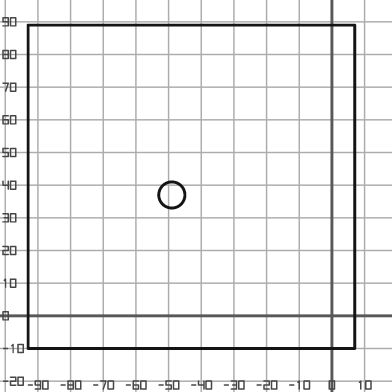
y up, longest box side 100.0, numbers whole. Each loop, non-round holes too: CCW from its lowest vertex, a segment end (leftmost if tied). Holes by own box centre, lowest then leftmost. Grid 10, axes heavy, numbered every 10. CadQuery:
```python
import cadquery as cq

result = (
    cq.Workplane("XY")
    .moveTo(-93.0, -10.0)
    .lineTo(7.0, -10.0)
    .lineTo(7.0, 89.0)
    .lineTo(-93.0, 89.0)
    .close()
    .moveTo(-49.0, 37.0)
    .circle(4.0)
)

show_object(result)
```